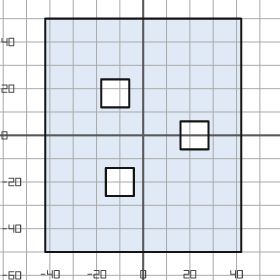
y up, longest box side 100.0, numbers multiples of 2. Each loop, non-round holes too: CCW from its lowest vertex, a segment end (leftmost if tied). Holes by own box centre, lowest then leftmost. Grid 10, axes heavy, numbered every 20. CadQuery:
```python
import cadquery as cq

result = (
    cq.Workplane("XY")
    .moveTo(-42.0, -50.0)
    .lineTo(42.0, -50.0)
    .lineTo(42.0, 50.0)
    .lineTo(-42.0, 50.0)
    .close()
    .moveTo(-16.0, -26.0)
    .lineTo(-4.0, -26.0)
    .lineTo(-4.0, -14.0)
    .lineTo(-16.0, -14.0)
    .close()
    .moveTo(16.0, -6.0)
    .lineTo(28.0, -6.0)
    .lineTo(28.0, 6.0)
    .lineTo(16.0, 6.0)
    .close()
    .moveTo(-18.0, 12.0)
    .lineTo(-6.0, 12.0)
    .lineTo(-6.0, 24.0)
    .lineTo(-18.0, 24.0)
    .close()
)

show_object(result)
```